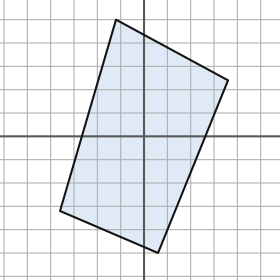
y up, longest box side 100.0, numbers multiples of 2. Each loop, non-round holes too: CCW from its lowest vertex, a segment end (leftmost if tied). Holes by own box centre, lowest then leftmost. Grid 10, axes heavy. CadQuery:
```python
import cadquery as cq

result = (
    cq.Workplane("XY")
    .moveTo(6.0, -50.0)
    .lineTo(36.0, 24.0)
    .lineTo(-12.0, 50.0)
    .lineTo(-36.0, -32.0)
    .close()
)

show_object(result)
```